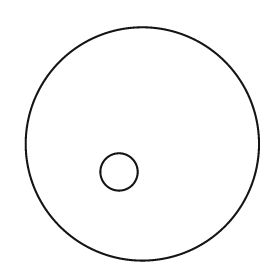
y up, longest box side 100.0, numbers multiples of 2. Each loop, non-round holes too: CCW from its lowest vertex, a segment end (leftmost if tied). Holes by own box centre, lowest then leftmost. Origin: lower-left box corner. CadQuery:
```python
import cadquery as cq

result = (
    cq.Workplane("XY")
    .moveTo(50.0, 50.0)
    .circle(50.0)
    .moveTo(40.0, 38.0)
    .circle(8.0)
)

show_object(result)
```